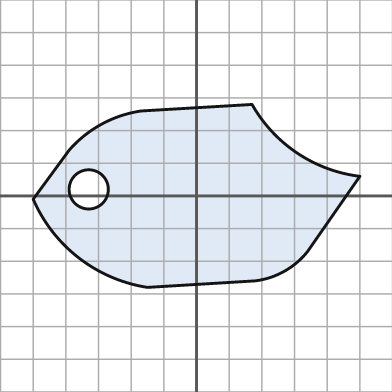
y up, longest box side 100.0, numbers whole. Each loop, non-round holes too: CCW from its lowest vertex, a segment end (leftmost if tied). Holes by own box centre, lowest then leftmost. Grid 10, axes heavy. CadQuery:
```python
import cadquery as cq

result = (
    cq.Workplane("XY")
    .moveTo(-15.0, -28.0)
    .lineTo(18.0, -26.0)
    .threePointArc((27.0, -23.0), (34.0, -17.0))
    .lineTo(50.0, 6.0)
    .threePointArc((31.0, 13.0), (17.0, 28.0))
    .lineTo(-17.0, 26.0)
    .threePointArc((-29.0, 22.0), (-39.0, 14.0))
    .lineTo(-50.0, -1.0)
    .threePointArc((-36.0, -19.0), (-15.0, -28.0))
    .close()
    .moveTo(-33.0, 2.0)
    .circle(6.0)
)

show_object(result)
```